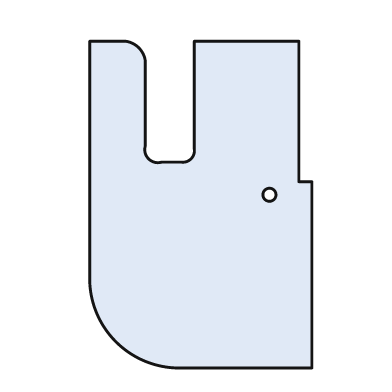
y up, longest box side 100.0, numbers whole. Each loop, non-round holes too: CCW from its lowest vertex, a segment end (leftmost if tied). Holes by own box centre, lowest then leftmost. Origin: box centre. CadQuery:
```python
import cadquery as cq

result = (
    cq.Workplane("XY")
    .moveTo(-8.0, -50.0)
    .lineTo(34.0, -50.0)
    .lineTo(34.0, 7.0)
    .lineTo(30.0, 7.0)
    .lineTo(30.0, 50.0)
    .lineTo(-2.0, 50.0)
    .lineTo(-2.0, 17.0)
    .threePointArc((-3.0, 14.0), (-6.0, 13.0))
    .lineTo(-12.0, 13.0)
    .threePointArc((-16.0, 14.0), (-17.0, 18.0))
    .lineTo(-17.0, 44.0)
    .threePointArc((-19.0, 48.0), (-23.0, 50.0))
    .lineTo(-34.0, 50.0)
    .lineTo(-34.0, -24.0)
    .threePointArc((-26.0, -42.0), (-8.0, -50.0))
    .close()
    .moveTo(21.0, 3.0)
    .circle(2.0)
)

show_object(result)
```